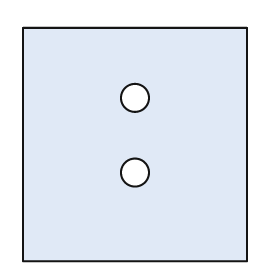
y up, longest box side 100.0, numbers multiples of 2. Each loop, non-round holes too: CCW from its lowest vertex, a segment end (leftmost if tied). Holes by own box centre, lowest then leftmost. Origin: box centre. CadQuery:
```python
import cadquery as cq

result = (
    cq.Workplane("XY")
    .moveTo(-48.0, -50.0)
    .lineTo(48.0, -50.0)
    .lineTo(48.0, 50.0)
    .lineTo(-48.0, 50.0)
    .close()
    .moveTo(0.0, -12.0)
    .circle(6.0)
    .moveTo(0.0, 20.0)
    .circle(6.0)
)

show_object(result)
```